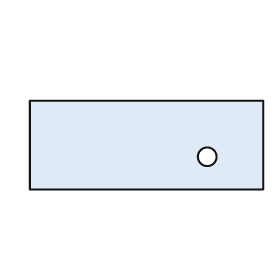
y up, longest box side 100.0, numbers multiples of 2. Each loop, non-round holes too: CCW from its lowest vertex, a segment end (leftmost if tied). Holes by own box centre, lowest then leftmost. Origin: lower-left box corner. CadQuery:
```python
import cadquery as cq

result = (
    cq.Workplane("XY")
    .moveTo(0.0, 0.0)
    .lineTo(100.0, 0.0)
    .lineTo(100.0, 38.0)
    .lineTo(0.0, 38.0)
    .close()
    .moveTo(76.0, 14.0)
    .circle(4.0)
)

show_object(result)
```